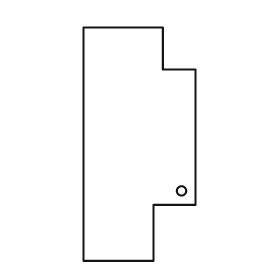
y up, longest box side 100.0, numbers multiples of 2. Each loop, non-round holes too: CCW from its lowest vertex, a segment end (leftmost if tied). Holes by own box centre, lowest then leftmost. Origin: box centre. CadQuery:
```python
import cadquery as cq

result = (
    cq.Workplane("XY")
    .moveTo(-24.0, -50.0)
    .lineTo(6.0, -50.0)
    .lineTo(6.0, -26.0)
    .lineTo(24.0, -26.0)
    .lineTo(24.0, 32.0)
    .lineTo(10.0, 32.0)
    .lineTo(10.0, 50.0)
    .lineTo(-24.0, 50.0)
    .close()
    .moveTo(18.0, -20.0)
    .circle(2.0)
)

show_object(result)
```